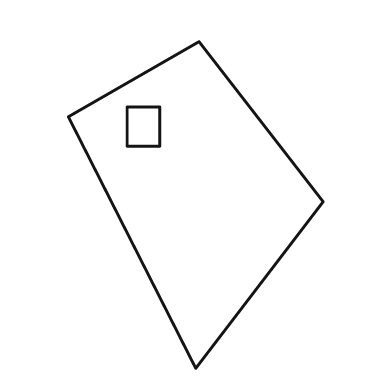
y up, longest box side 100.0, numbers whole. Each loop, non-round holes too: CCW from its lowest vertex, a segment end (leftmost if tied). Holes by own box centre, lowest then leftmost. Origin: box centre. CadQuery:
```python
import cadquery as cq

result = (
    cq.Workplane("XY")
    .moveTo(0.0, -50.0)
    .lineTo(39.0, 1.0)
    .lineTo(1.0, 50.0)
    .lineTo(-39.0, 27.0)
    .close()
    .moveTo(-21.0, 18.0)
    .lineTo(-11.0, 18.0)
    .lineTo(-11.0, 30.0)
    .lineTo(-21.0, 30.0)
    .close()
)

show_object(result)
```